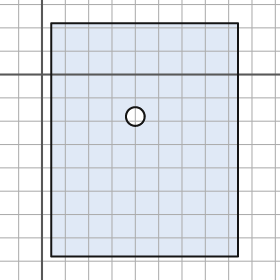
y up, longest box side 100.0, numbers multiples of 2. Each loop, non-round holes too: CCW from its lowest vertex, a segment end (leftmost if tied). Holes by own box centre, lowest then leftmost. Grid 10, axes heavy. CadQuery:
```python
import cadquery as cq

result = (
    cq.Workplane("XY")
    .moveTo(4.0, -78.0)
    .lineTo(84.0, -78.0)
    .lineTo(84.0, 22.0)
    .lineTo(4.0, 22.0)
    .close()
    .moveTo(40.0, -18.0)
    .circle(4.0)
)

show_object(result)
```